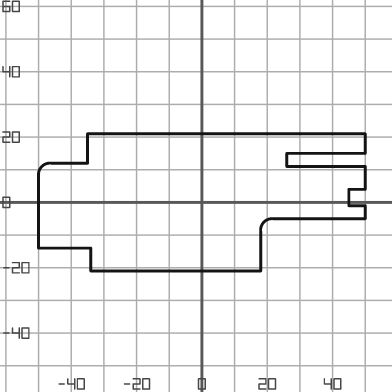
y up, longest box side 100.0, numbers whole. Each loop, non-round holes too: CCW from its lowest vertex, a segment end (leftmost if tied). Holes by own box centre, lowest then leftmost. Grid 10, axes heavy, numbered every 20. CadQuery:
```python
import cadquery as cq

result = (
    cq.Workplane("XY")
    .moveTo(-34.0, -21.0)
    .lineTo(18.0, -21.0)
    .lineTo(18.0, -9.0)
    .threePointArc((19.0, -6.0), (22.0, -5.0))
    .lineTo(50.0, -5.0)
    .lineTo(50.0, -1.0)
    .lineTo(45.0, -1.0)
    .lineTo(45.0, 4.0)
    .lineTo(50.0, 4.0)
    .lineTo(50.0, 11.0)
    .lineTo(26.0, 11.0)
    .lineTo(26.0, 15.0)
    .lineTo(50.0, 15.0)
    .lineTo(50.0, 21.0)
    .lineTo(-35.0, 21.0)
    .lineTo(-35.0, 12.0)
    .lineTo(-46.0, 12.0)
    .threePointArc((-49.0, 11.0), (-50.0, 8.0))
    .lineTo(-50.0, -14.0)
    .lineTo(-34.0, -14.0)
    .close()
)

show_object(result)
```